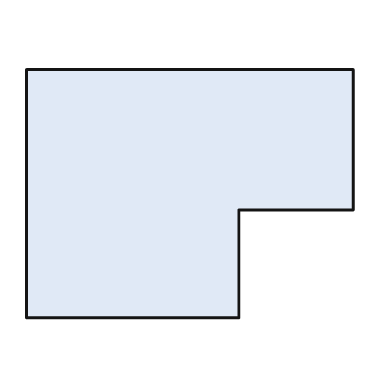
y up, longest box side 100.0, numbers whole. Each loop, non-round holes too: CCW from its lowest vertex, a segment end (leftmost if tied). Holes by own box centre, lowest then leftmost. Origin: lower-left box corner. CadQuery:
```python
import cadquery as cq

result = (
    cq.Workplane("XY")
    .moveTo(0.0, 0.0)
    .lineTo(65.0, 0.0)
    .lineTo(65.0, 33.0)
    .lineTo(100.0, 33.0)
    .lineTo(100.0, 76.0)
    .lineTo(0.0, 76.0)
    .close()
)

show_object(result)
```